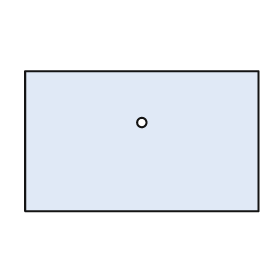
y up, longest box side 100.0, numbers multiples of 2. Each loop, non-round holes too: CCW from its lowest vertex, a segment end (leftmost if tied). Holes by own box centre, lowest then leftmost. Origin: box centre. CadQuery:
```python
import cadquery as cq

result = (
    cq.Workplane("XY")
    .moveTo(-50.0, -30.0)
    .lineTo(50.0, -30.0)
    .lineTo(50.0, 30.0)
    .lineTo(-50.0, 30.0)
    .close()
    .moveTo(0.0, 8.0)
    .circle(2.0)
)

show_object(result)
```